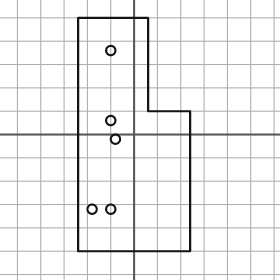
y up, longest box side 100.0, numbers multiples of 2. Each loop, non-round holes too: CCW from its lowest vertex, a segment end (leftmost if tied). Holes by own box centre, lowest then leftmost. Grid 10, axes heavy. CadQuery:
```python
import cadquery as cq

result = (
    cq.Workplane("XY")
    .moveTo(-24.0, -50.0)
    .lineTo(24.0, -50.0)
    .lineTo(24.0, 10.0)
    .lineTo(6.0, 10.0)
    .lineTo(6.0, 50.0)
    .lineTo(-24.0, 50.0)
    .close()
    .moveTo(-18.0, -32.0)
    .circle(2.0)
    .moveTo(-10.0, -32.0)
    .circle(2.0)
    .moveTo(-8.0, -2.0)
    .circle(2.0)
    .moveTo(-10.0, 6.0)
    .circle(2.0)
    .moveTo(-10.0, 36.0)
    .circle(2.0)
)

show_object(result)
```